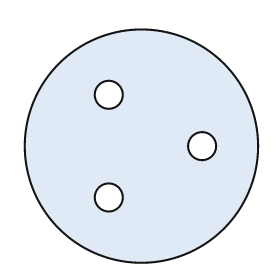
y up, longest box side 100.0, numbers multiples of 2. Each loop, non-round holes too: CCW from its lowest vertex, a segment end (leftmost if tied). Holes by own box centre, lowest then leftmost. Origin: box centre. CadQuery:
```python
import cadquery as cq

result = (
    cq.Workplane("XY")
    .moveTo(0.0, 0.0)
    .circle(50.0)
    .moveTo(-14.0, -22.0)
    .circle(6.0)
    .moveTo(26.0, 0.0)
    .circle(6.0)
    .moveTo(-14.0, 22.0)
    .circle(6.0)
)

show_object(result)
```